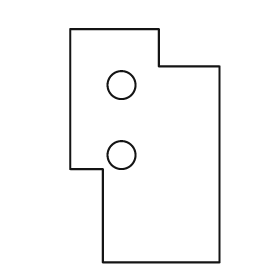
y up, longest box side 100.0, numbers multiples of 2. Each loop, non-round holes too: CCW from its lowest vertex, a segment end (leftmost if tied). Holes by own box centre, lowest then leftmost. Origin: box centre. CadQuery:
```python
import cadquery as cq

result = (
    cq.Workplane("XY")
    .moveTo(-18.0, -50.0)
    .lineTo(32.0, -50.0)
    .lineTo(32.0, 34.0)
    .lineTo(6.0, 34.0)
    .lineTo(6.0, 50.0)
    .lineTo(-32.0, 50.0)
    .lineTo(-32.0, -10.0)
    .lineTo(-18.0, -10.0)
    .close()
    .moveTo(-10.0, -4.0)
    .circle(6.0)
    .moveTo(-10.0, 26.0)
    .circle(6.0)
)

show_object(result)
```